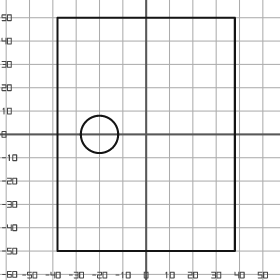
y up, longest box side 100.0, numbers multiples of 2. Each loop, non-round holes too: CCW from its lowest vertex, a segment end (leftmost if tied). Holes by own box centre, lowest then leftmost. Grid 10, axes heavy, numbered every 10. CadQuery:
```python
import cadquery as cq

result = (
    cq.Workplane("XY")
    .moveTo(-38.0, -50.0)
    .lineTo(38.0, -50.0)
    .lineTo(38.0, 50.0)
    .lineTo(-38.0, 50.0)
    .close()
    .moveTo(-20.0, 0.0)
    .circle(8.0)
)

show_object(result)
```